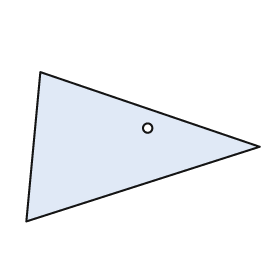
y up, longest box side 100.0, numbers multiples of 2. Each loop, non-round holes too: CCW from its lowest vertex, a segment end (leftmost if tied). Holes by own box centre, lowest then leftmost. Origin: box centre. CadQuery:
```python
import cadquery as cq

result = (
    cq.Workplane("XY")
    .moveTo(-50.0, -32.0)
    .lineTo(50.0, 0.0)
    .lineTo(-44.0, 32.0)
    .close()
    .moveTo(2.0, 8.0)
    .circle(2.0)
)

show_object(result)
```